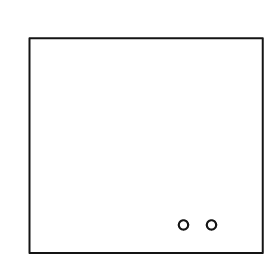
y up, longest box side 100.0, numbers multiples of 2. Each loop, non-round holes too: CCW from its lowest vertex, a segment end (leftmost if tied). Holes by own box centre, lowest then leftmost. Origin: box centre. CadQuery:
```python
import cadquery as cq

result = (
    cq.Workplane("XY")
    .moveTo(-50.0, -46.0)
    .lineTo(50.0, -46.0)
    .lineTo(50.0, 46.0)
    .lineTo(-50.0, 46.0)
    .close()
    .moveTo(16.0, -34.0)
    .circle(2.0)
    .moveTo(28.0, -34.0)
    .circle(2.0)
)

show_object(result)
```